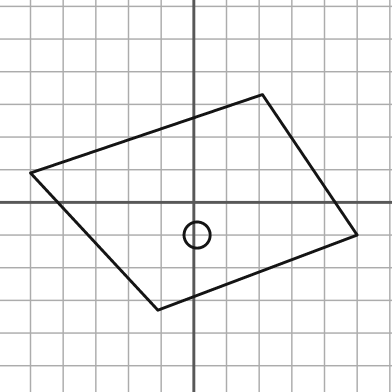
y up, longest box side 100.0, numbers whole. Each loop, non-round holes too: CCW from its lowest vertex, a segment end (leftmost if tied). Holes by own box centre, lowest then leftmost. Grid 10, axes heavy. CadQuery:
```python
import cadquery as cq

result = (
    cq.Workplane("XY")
    .moveTo(-11.0, -33.0)
    .lineTo(50.0, -10.0)
    .lineTo(21.0, 33.0)
    .lineTo(-50.0, 9.0)
    .close()
    .moveTo(1.0, -10.0)
    .circle(4.0)
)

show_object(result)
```